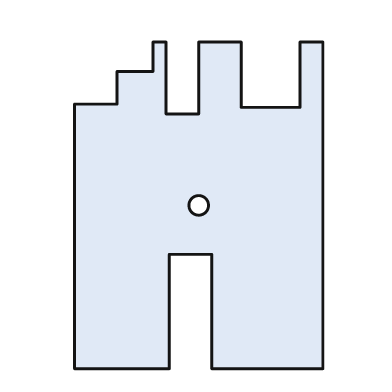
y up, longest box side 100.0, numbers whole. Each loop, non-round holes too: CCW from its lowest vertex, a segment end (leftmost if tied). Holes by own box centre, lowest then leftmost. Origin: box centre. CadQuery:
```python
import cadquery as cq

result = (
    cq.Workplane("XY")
    .moveTo(-38.0, -50.0)
    .lineTo(-9.0, -50.0)
    .lineTo(-9.0, -15.0)
    .lineTo(4.0, -15.0)
    .lineTo(4.0, -50.0)
    .lineTo(38.0, -50.0)
    .lineTo(38.0, 50.0)
    .lineTo(31.0, 50.0)
    .lineTo(31.0, 30.0)
    .lineTo(13.0, 30.0)
    .lineTo(13.0, 50.0)
    .lineTo(0.0, 50.0)
    .lineTo(0.0, 28.0)
    .lineTo(-10.0, 28.0)
    .lineTo(-10.0, 50.0)
    .lineTo(-14.0, 50.0)
    .lineTo(-14.0, 41.0)
    .lineTo(-25.0, 41.0)
    .lineTo(-25.0, 31.0)
    .lineTo(-38.0, 31.0)
    .close()
    .moveTo(0.0, 0.0)
    .circle(3.0)
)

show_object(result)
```